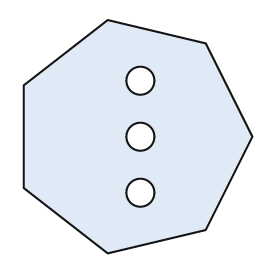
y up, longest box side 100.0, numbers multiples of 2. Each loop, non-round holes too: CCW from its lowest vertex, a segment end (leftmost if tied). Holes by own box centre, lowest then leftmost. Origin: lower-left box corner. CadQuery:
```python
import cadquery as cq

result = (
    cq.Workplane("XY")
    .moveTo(36.0, 0.0)
    .lineTo(78.0, 10.0)
    .lineTo(98.0, 50.0)
    .lineTo(78.0, 90.0)
    .lineTo(36.0, 100.0)
    .lineTo(0.0, 72.0)
    .lineTo(0.0, 28.0)
    .close()
    .moveTo(50.0, 26.0)
    .circle(6.0)
    .moveTo(50.0, 50.0)
    .circle(6.0)
    .moveTo(50.0, 74.0)
    .circle(6.0)
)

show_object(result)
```